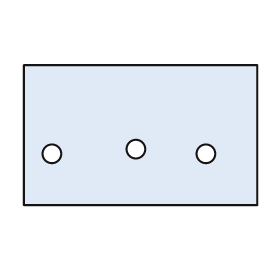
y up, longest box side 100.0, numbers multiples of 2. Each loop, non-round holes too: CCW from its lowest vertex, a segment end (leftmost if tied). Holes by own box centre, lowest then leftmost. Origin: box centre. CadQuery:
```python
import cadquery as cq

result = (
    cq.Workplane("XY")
    .moveTo(-50.0, -30.0)
    .lineTo(50.0, -30.0)
    .lineTo(50.0, 30.0)
    .lineTo(-50.0, 30.0)
    .close()
    .moveTo(-38.0, -8.0)
    .circle(4.0)
    .moveTo(28.0, -8.0)
    .circle(4.0)
    .moveTo(-2.0, -6.0)
    .circle(4.0)
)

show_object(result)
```